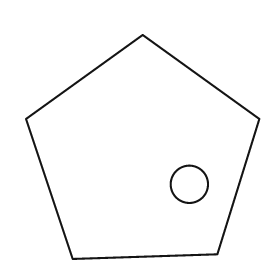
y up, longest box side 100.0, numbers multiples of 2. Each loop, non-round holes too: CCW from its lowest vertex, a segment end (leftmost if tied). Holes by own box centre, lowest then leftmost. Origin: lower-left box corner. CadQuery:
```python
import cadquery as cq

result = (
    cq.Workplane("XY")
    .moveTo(20.0, 0.0)
    .lineTo(82.0, 2.0)
    .lineTo(100.0, 60.0)
    .lineTo(50.0, 96.0)
    .lineTo(0.0, 60.0)
    .close()
    .moveTo(70.0, 32.0)
    .circle(8.0)
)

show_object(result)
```